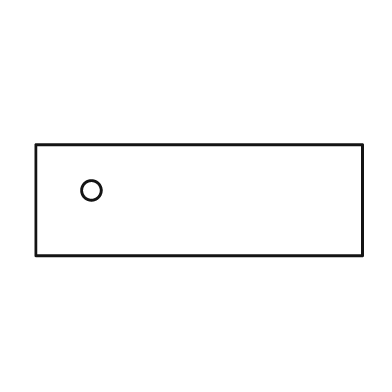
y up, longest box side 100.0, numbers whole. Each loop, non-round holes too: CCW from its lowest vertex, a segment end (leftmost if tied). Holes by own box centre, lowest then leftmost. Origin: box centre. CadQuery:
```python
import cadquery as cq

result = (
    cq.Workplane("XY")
    .moveTo(-50.0, -17.0)
    .lineTo(50.0, -17.0)
    .lineTo(50.0, 17.0)
    .lineTo(-50.0, 17.0)
    .close()
    .moveTo(-33.0, 3.0)
    .circle(3.0)
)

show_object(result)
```